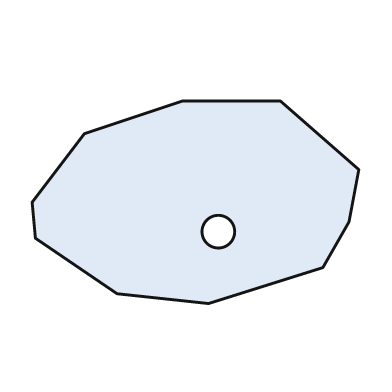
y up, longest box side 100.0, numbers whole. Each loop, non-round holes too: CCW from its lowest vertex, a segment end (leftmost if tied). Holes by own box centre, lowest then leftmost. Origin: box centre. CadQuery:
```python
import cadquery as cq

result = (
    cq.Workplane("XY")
    .moveTo(4.0, -31.0)
    .lineTo(39.0, -20.0)
    .lineTo(47.0, -6.0)
    .lineTo(50.0, 10.0)
    .lineTo(26.0, 31.0)
    .lineTo(-4.0, 31.0)
    .lineTo(-34.0, 21.0)
    .lineTo(-50.0, 0.0)
    .lineTo(-49.0, -11.0)
    .lineTo(-24.0, -28.0)
    .close()
    .moveTo(7.0, -9.0)
    .circle(5.0)
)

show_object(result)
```